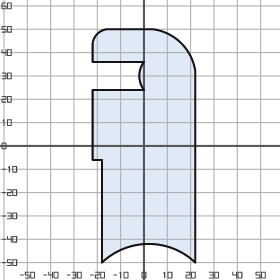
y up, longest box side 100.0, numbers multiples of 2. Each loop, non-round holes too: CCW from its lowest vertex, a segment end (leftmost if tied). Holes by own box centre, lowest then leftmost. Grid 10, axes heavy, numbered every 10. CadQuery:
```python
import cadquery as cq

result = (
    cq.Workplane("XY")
    .moveTo(-18.0, -50.0)
    .threePointArc((2.0, -42.0), (22.0, -50.0))
    .lineTo(22.0, 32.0)
    .threePointArc((16.0, 44.0), (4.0, 50.0))
    .lineTo(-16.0, 50.0)
    .threePointArc((-20.0, 48.0), (-22.0, 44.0))
    .lineTo(-22.0, 36.0)
    .lineTo(0.0, 36.0)
    .threePointArc((-2.0, 30.0), (0.0, 24.0))
    .lineTo(-22.0, 24.0)
    .lineTo(-22.0, -6.0)
    .lineTo(-18.0, -6.0)
    .close()
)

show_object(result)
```